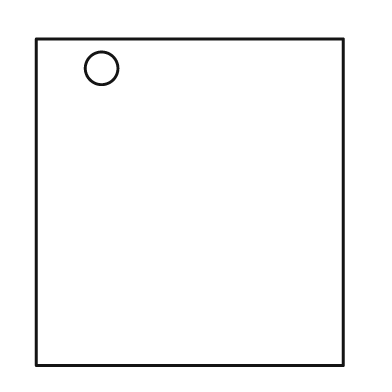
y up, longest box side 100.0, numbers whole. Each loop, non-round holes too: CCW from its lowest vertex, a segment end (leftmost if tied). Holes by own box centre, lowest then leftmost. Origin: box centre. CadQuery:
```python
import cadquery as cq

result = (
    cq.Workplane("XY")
    .moveTo(-47.0, -50.0)
    .lineTo(47.0, -50.0)
    .lineTo(47.0, 50.0)
    .lineTo(-47.0, 50.0)
    .close()
    .moveTo(-27.0, 41.0)
    .circle(5.0)
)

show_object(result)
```